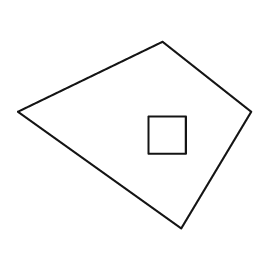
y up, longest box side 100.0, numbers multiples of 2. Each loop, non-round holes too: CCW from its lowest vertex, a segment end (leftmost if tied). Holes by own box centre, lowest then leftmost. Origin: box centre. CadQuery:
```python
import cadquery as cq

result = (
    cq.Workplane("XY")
    .moveTo(20.0, -40.0)
    .lineTo(50.0, 10.0)
    .lineTo(12.0, 40.0)
    .lineTo(-50.0, 10.0)
    .close()
    .moveTo(6.0, -8.0)
    .lineTo(22.0, -8.0)
    .lineTo(22.0, 8.0)
    .lineTo(6.0, 8.0)
    .close()
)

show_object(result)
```